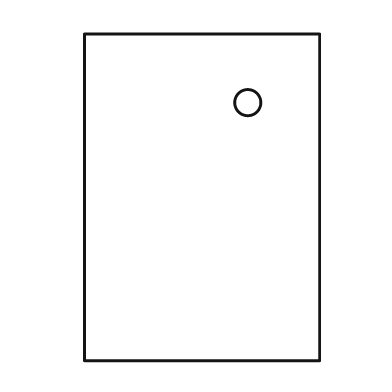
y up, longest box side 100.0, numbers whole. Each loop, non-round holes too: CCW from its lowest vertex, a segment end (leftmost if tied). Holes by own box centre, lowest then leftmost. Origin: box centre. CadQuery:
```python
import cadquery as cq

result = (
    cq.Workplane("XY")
    .moveTo(-36.0, -50.0)
    .lineTo(36.0, -50.0)
    .lineTo(36.0, 50.0)
    .lineTo(-36.0, 50.0)
    .close()
    .moveTo(14.0, 29.0)
    .circle(4.0)
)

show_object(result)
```